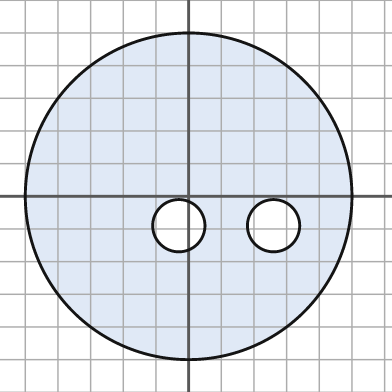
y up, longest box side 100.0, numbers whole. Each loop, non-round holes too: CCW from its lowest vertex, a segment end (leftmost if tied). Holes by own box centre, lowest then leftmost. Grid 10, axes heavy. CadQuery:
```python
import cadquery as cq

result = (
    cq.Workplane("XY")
    .moveTo(0.0, 0.0)
    .circle(50.0)
    .moveTo(-3.0, -9.0)
    .circle(8.0)
    .moveTo(26.0, -9.0)
    .circle(8.0)
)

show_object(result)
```